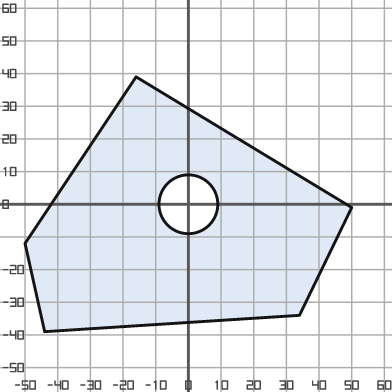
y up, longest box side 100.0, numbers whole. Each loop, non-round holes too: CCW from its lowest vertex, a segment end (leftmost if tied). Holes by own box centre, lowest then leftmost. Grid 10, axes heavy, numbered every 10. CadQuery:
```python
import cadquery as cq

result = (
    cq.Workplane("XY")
    .moveTo(-44.0, -39.0)
    .lineTo(34.0, -34.0)
    .lineTo(50.0, -1.0)
    .lineTo(-16.0, 39.0)
    .lineTo(-50.0, -12.0)
    .close()
    .moveTo(0.0, 0.0)
    .circle(9.0)
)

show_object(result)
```